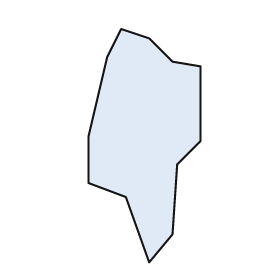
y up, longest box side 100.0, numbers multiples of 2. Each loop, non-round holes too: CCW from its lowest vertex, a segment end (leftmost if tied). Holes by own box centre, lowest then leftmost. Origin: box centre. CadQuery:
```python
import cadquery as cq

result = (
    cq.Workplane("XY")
    .moveTo(2.0, -50.0)
    .lineTo(12.0, -38.0)
    .lineTo(14.0, -8.0)
    .lineTo(24.0, 2.0)
    .lineTo(24.0, 34.0)
    .lineTo(12.0, 36.0)
    .lineTo(2.0, 46.0)
    .lineTo(-10.0, 50.0)
    .lineTo(-16.0, 38.0)
    .lineTo(-24.0, 4.0)
    .lineTo(-24.0, -16.0)
    .lineTo(-8.0, -22.0)
    .close()
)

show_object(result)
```